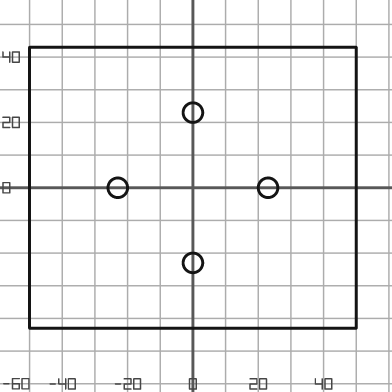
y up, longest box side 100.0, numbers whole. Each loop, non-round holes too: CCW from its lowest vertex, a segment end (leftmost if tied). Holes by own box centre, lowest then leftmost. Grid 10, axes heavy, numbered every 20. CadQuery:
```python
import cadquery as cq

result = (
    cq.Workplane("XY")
    .moveTo(-50.0, -43.0)
    .lineTo(50.0, -43.0)
    .lineTo(50.0, 43.0)
    .lineTo(-50.0, 43.0)
    .close()
    .moveTo(0.0, -23.0)
    .circle(3.0)
    .moveTo(-23.0, 0.0)
    .circle(3.0)
    .moveTo(23.0, 0.0)
    .circle(3.0)
    .moveTo(0.0, 23.0)
    .circle(3.0)
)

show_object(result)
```